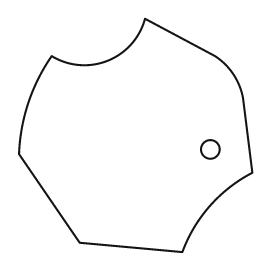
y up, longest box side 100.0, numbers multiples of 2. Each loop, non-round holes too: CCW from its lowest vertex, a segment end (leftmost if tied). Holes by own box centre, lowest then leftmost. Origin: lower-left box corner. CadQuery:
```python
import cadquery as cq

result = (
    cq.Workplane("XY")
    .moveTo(70.0, 0.0)
    .threePointArc((82.0, 20.0), (100.0, 34.0))
    .lineTo(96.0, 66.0)
    .threePointArc((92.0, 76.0), (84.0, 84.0))
    .lineTo(54.0, 100.0)
    .threePointArc((38.0, 82.0), (14.0, 84.0))
    .threePointArc((4.0, 64.0), (0.0, 42.0))
    .lineTo(26.0, 4.0)
    .close()
    .moveTo(82.0, 44.0)
    .circle(4.0)
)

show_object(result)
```